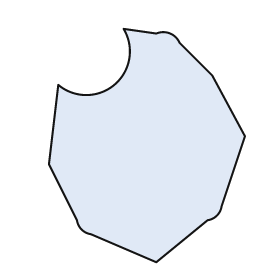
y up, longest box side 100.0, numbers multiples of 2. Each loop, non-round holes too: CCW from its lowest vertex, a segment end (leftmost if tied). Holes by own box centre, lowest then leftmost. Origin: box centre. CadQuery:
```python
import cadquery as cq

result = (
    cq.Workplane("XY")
    .moveTo(4.0, -50.0)
    .lineTo(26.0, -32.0)
    .threePointArc((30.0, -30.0), (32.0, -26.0))
    .lineTo(42.0, 4.0)
    .lineTo(28.0, 30.0)
    .lineTo(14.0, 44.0)
    .threePointArc((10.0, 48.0), (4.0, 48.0))
    .lineTo(-10.0, 50.0)
    .threePointArc((-14.0, 26.0), (-38.0, 26.0))
    .lineTo(-42.0, -8.0)
    .lineTo(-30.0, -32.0)
    .threePointArc((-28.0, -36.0), (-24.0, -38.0))
    .close()
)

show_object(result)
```